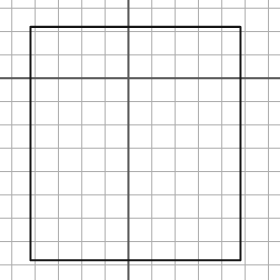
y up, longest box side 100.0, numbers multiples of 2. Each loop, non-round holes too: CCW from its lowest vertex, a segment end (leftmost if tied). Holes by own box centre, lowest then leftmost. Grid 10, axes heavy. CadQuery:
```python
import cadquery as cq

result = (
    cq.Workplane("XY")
    .moveTo(-42.0, -78.0)
    .lineTo(48.0, -78.0)
    .lineTo(48.0, 22.0)
    .lineTo(-42.0, 22.0)
    .close()
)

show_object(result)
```